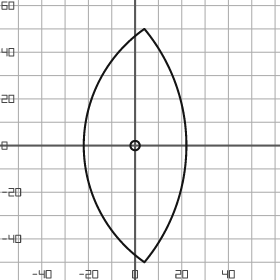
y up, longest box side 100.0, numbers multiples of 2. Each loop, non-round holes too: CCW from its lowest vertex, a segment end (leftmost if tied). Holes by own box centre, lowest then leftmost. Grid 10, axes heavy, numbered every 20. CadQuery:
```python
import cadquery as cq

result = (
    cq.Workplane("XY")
    .moveTo(4.0, -50.0)
    .threePointArc((22.0, 0.0), (4.0, 50.0))
    .threePointArc((-22.0, 0.0), (4.0, -50.0))
    .close()
    .moveTo(0.0, 0.0)
    .circle(2.0)
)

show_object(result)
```